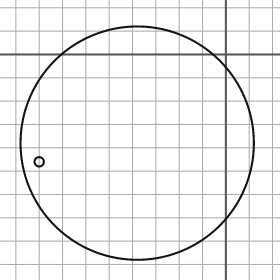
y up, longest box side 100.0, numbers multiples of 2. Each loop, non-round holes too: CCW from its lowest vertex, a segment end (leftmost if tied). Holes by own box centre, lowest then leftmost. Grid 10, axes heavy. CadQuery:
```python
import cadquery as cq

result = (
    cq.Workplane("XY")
    .moveTo(-38.0, -38.0)
    .circle(50.0)
    .moveTo(-80.0, -46.0)
    .circle(2.0)
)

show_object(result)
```